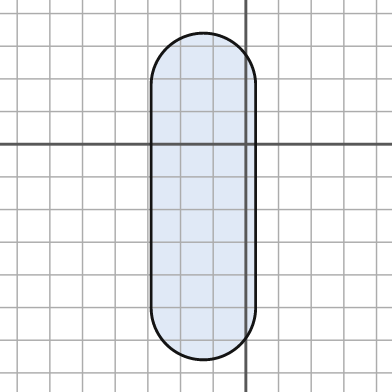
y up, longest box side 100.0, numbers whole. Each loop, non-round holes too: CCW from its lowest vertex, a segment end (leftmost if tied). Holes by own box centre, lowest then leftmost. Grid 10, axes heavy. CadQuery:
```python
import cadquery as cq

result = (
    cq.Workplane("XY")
    .moveTo(-29.0, -50.0)
    .threePointArc((-13.0, -66.0), (3.0, -50.0))
    .lineTo(3.0, 18.0)
    .threePointArc((-13.0, 34.0), (-29.0, 18.0))
    .close()
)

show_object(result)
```